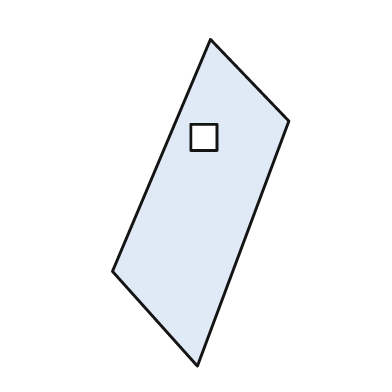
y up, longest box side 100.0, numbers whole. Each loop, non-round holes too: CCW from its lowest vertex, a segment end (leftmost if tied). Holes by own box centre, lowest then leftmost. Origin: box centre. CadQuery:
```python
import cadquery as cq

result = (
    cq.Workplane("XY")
    .moveTo(-1.0, -50.0)
    .lineTo(27.0, 25.0)
    .lineTo(3.0, 50.0)
    .lineTo(-27.0, -21.0)
    .close()
    .moveTo(-3.0, 16.0)
    .lineTo(5.0, 16.0)
    .lineTo(5.0, 24.0)
    .lineTo(-3.0, 24.0)
    .close()
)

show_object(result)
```